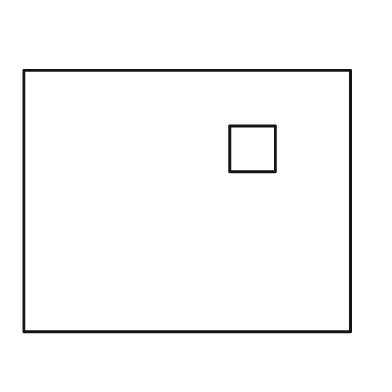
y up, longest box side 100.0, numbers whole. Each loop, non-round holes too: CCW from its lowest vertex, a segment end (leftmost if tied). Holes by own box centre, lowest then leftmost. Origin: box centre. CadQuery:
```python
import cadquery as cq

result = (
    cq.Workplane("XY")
    .moveTo(-50.0, -40.0)
    .lineTo(50.0, -40.0)
    .lineTo(50.0, 40.0)
    .lineTo(-50.0, 40.0)
    .close()
    .moveTo(13.0, 9.0)
    .lineTo(27.0, 9.0)
    .lineTo(27.0, 23.0)
    .lineTo(13.0, 23.0)
    .close()
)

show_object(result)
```